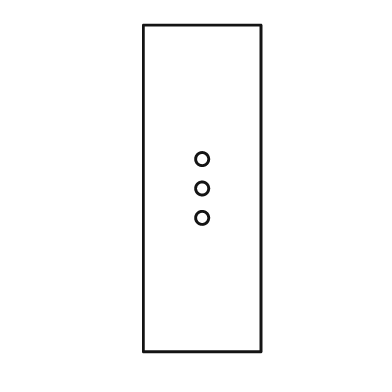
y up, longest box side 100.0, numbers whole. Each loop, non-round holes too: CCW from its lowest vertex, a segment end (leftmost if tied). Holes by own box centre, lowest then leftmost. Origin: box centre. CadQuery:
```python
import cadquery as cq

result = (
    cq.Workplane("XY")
    .moveTo(-18.0, -50.0)
    .lineTo(18.0, -50.0)
    .lineTo(18.0, 50.0)
    .lineTo(-18.0, 50.0)
    .close()
    .moveTo(0.0, -9.0)
    .circle(2.0)
    .moveTo(0.0, 0.0)
    .circle(2.0)
    .moveTo(0.0, 9.0)
    .circle(2.0)
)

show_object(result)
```